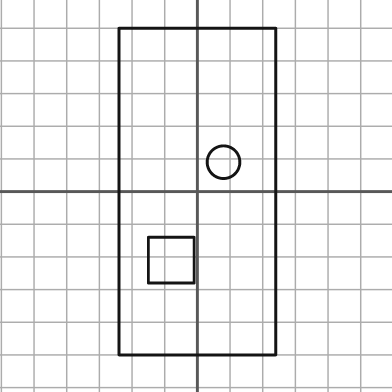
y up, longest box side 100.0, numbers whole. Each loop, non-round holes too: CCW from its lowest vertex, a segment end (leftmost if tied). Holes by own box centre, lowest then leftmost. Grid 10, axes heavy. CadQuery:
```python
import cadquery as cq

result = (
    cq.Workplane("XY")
    .moveTo(-24.0, -50.0)
    .lineTo(24.0, -50.0)
    .lineTo(24.0, 50.0)
    .lineTo(-24.0, 50.0)
    .close()
    .moveTo(-15.0, -28.0)
    .lineTo(-1.0, -28.0)
    .lineTo(-1.0, -14.0)
    .lineTo(-15.0, -14.0)
    .close()
    .moveTo(8.0, 9.0)
    .circle(5.0)
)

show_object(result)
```